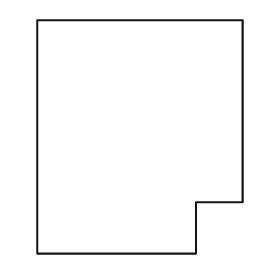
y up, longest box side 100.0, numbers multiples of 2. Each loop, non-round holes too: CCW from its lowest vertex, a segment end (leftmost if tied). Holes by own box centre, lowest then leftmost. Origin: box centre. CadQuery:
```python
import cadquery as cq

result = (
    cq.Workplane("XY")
    .moveTo(-44.0, -50.0)
    .lineTo(24.0, -50.0)
    .lineTo(24.0, -28.0)
    .lineTo(44.0, -28.0)
    .lineTo(44.0, 50.0)
    .lineTo(-44.0, 50.0)
    .close()
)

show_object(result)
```